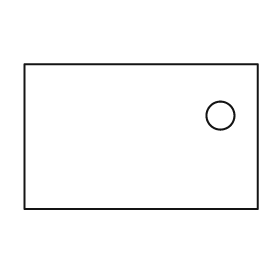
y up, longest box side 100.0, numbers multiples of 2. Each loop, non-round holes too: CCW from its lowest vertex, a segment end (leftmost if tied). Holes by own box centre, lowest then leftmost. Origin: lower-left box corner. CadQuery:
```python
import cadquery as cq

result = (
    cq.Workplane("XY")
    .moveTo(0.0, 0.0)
    .lineTo(100.0, 0.0)
    .lineTo(100.0, 62.0)
    .lineTo(0.0, 62.0)
    .close()
    .moveTo(84.0, 40.0)
    .circle(6.0)
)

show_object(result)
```